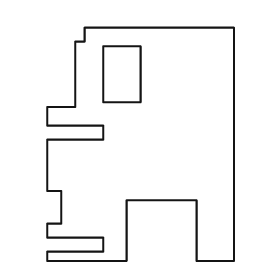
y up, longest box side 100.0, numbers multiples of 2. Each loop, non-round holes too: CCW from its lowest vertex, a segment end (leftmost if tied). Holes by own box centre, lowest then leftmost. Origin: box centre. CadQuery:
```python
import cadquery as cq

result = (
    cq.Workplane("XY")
    .moveTo(-40.0, -50.0)
    .lineTo(-6.0, -50.0)
    .lineTo(-6.0, -24.0)
    .lineTo(24.0, -24.0)
    .lineTo(24.0, -50.0)
    .lineTo(40.0, -50.0)
    .lineTo(40.0, 50.0)
    .lineTo(-24.0, 50.0)
    .lineTo(-24.0, 44.0)
    .lineTo(-28.0, 44.0)
    .lineTo(-28.0, 16.0)
    .lineTo(-40.0, 16.0)
    .lineTo(-40.0, 8.0)
    .lineTo(-16.0, 8.0)
    .lineTo(-16.0, 2.0)
    .lineTo(-40.0, 2.0)
    .lineTo(-40.0, -20.0)
    .lineTo(-34.0, -20.0)
    .lineTo(-34.0, -34.0)
    .lineTo(-40.0, -34.0)
    .lineTo(-40.0, -40.0)
    .lineTo(-16.0, -40.0)
    .lineTo(-16.0, -46.0)
    .lineTo(-40.0, -46.0)
    .close()
    .moveTo(-16.0, 18.0)
    .lineTo(0.0, 18.0)
    .lineTo(0.0, 42.0)
    .lineTo(-16.0, 42.0)
    .close()
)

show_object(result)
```